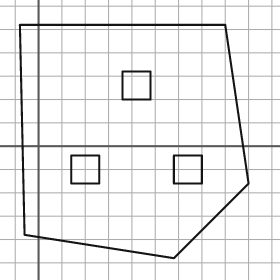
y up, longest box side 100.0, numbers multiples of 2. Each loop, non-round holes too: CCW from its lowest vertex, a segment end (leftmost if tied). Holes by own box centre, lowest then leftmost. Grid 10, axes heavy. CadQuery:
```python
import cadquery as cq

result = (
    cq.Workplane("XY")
    .moveTo(58.0, -48.0)
    .lineTo(90.0, -16.0)
    .lineTo(80.0, 52.0)
    .lineTo(-8.0, 52.0)
    .lineTo(-6.0, -38.0)
    .close()
    .moveTo(14.0, -16.0)
    .lineTo(26.0, -16.0)
    .lineTo(26.0, -4.0)
    .lineTo(14.0, -4.0)
    .close()
    .moveTo(58.0, -16.0)
    .lineTo(70.0, -16.0)
    .lineTo(70.0, -4.0)
    .lineTo(58.0, -4.0)
    .close()
    .moveTo(36.0, 20.0)
    .lineTo(48.0, 20.0)
    .lineTo(48.0, 32.0)
    .lineTo(36.0, 32.0)
    .close()
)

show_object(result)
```